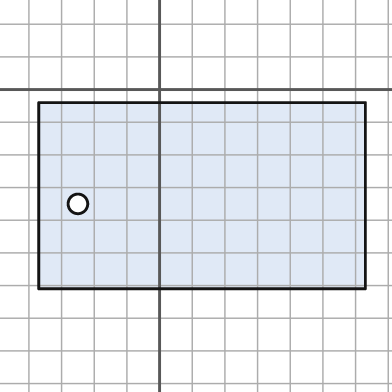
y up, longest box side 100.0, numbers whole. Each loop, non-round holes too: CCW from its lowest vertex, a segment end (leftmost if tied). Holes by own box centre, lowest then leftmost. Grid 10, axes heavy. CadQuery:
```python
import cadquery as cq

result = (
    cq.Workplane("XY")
    .moveTo(-37.0, -61.0)
    .lineTo(63.0, -61.0)
    .lineTo(63.0, -4.0)
    .lineTo(-37.0, -4.0)
    .close()
    .moveTo(-25.0, -35.0)
    .circle(3.0)
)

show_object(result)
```